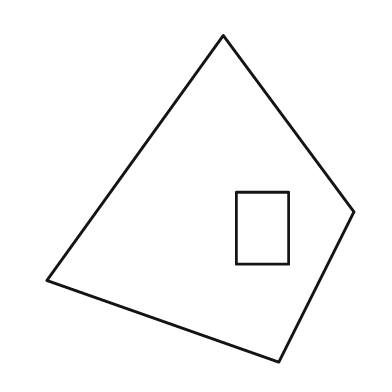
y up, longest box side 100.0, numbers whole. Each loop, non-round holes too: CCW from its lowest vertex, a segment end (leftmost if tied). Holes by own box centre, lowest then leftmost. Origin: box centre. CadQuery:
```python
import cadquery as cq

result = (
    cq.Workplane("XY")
    .moveTo(24.0, -50.0)
    .lineTo(47.0, -4.0)
    .lineTo(7.0, 50.0)
    .lineTo(-47.0, -25.0)
    .close()
    .moveTo(11.0, -20.0)
    .lineTo(27.0, -20.0)
    .lineTo(27.0, 2.0)
    .lineTo(11.0, 2.0)
    .close()
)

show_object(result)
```